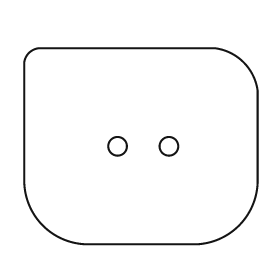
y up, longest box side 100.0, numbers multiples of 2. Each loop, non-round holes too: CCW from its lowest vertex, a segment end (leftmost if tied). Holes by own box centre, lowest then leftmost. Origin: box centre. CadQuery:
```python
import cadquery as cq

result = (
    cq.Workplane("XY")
    .moveTo(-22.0, -42.0)
    .lineTo(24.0, -42.0)
    .threePointArc((42.0, -34.0), (50.0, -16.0))
    .lineTo(50.0, 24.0)
    .threePointArc((44.0, 36.0), (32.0, 42.0))
    .lineTo(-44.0, 42.0)
    .threePointArc((-48.0, 40.0), (-50.0, 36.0))
    .lineTo(-50.0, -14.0)
    .threePointArc((-42.0, -34.0), (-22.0, -42.0))
    .close()
    .moveTo(-10.0, 0.0)
    .circle(4.0)
    .moveTo(12.0, 0.0)
    .circle(4.0)
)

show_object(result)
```